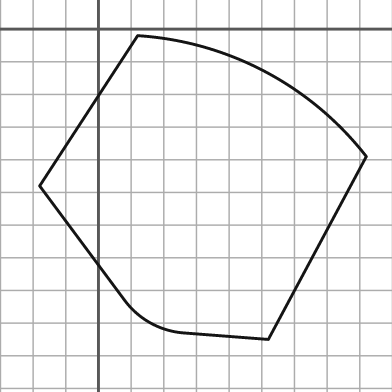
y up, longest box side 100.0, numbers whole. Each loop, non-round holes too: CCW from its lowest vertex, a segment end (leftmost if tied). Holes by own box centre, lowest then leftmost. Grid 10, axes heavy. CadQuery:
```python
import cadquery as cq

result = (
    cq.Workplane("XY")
    .moveTo(52.0, -95.0)
    .lineTo(82.0, -39.0)
    .threePointArc((51.0, -13.0), (12.0, -2.0))
    .lineTo(-18.0, -48.0)
    .lineTo(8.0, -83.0)
    .threePointArc((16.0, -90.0), (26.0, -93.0))
    .close()
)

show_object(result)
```